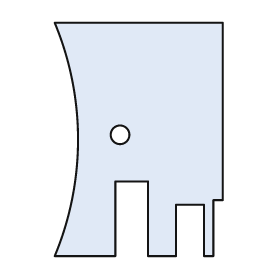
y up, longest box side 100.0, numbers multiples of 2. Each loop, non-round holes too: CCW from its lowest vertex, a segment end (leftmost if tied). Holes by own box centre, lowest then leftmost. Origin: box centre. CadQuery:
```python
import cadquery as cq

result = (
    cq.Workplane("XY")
    .moveTo(-36.0, -50.0)
    .lineTo(-10.0, -50.0)
    .lineTo(-10.0, -18.0)
    .lineTo(4.0, -18.0)
    .lineTo(4.0, -50.0)
    .lineTo(16.0, -50.0)
    .lineTo(16.0, -28.0)
    .lineTo(28.0, -28.0)
    .lineTo(28.0, -50.0)
    .lineTo(32.0, -50.0)
    .lineTo(32.0, -26.0)
    .lineTo(36.0, -26.0)
    .lineTo(36.0, 50.0)
    .lineTo(-36.0, 50.0)
    .threePointArc((-26.0, 0.0), (-36.0, -50.0))
    .close()
    .moveTo(-8.0, 2.0)
    .circle(4.0)
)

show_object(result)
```